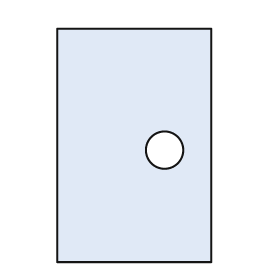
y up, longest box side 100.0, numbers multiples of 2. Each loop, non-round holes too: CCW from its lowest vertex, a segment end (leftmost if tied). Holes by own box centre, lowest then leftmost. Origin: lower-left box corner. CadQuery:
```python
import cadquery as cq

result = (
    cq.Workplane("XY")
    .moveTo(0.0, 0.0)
    .lineTo(66.0, 0.0)
    .lineTo(66.0, 100.0)
    .lineTo(0.0, 100.0)
    .close()
    .moveTo(46.0, 48.0)
    .circle(8.0)
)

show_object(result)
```